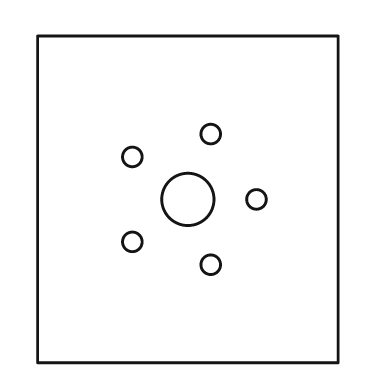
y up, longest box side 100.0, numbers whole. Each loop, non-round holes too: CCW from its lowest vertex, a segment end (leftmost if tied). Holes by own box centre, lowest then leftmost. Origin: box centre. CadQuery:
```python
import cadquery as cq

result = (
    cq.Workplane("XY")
    .moveTo(-46.0, -50.0)
    .lineTo(46.0, -50.0)
    .lineTo(46.0, 50.0)
    .lineTo(-46.0, 50.0)
    .close()
    .moveTo(7.0, -20.0)
    .circle(3.0)
    .moveTo(-17.0, -13.0)
    .circle(3.0)
    .moveTo(0.0, 0.0)
    .circle(8.0)
    .moveTo(21.0, 0.0)
    .circle(3.0)
    .moveTo(-17.0, 13.0)
    .circle(3.0)
    .moveTo(7.0, 20.0)
    .circle(3.0)
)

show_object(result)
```